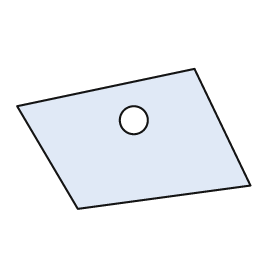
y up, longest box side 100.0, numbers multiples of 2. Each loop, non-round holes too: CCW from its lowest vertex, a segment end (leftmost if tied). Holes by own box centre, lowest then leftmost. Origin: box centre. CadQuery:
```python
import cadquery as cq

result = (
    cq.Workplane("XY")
    .moveTo(-24.0, -30.0)
    .lineTo(50.0, -20.0)
    .lineTo(26.0, 30.0)
    .lineTo(-50.0, 14.0)
    .close()
    .moveTo(0.0, 8.0)
    .circle(6.0)
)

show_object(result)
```